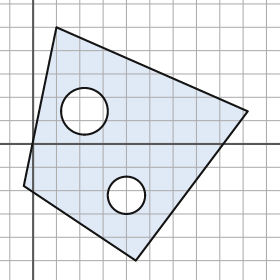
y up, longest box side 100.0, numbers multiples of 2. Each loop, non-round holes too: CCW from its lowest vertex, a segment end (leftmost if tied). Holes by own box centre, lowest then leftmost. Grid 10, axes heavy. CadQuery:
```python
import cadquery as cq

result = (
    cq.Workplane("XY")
    .moveTo(44.0, -50.0)
    .lineTo(92.0, 14.0)
    .lineTo(10.0, 50.0)
    .lineTo(-4.0, -18.0)
    .close()
    .moveTo(40.0, -22.0)
    .circle(8.0)
    .moveTo(22.0, 14.0)
    .circle(10.0)
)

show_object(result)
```